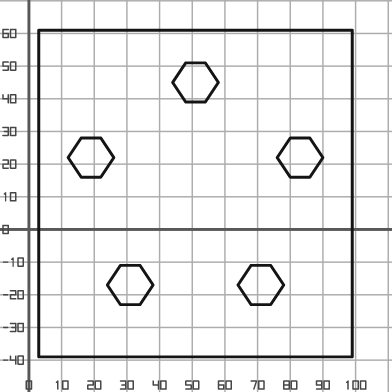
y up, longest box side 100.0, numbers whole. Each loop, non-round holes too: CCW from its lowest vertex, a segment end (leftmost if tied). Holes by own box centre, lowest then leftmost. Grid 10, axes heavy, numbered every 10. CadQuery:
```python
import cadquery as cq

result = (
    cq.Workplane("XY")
    .moveTo(3.0, -39.0)
    .lineTo(99.0, -39.0)
    .lineTo(99.0, 61.0)
    .lineTo(3.0, 61.0)
    .close()
    .moveTo(28.0, -23.0)
    .lineTo(34.0, -23.0)
    .lineTo(38.0, -17.0)
    .lineTo(34.0, -11.0)
    .lineTo(28.0, -11.0)
    .lineTo(24.0, -17.0)
    .close()
    .moveTo(68.0, -23.0)
    .lineTo(74.0, -23.0)
    .lineTo(78.0, -17.0)
    .lineTo(74.0, -11.0)
    .lineTo(68.0, -11.0)
    .lineTo(64.0, -17.0)
    .close()
    .moveTo(16.0, 16.0)
    .lineTo(22.0, 16.0)
    .lineTo(26.0, 22.0)
    .lineTo(22.0, 28.0)
    .lineTo(16.0, 28.0)
    .lineTo(12.0, 22.0)
    .close()
    .moveTo(80.0, 16.0)
    .lineTo(86.0, 16.0)
    .lineTo(90.0, 22.0)
    .lineTo(86.0, 28.0)
    .lineTo(80.0, 28.0)
    .lineTo(76.0, 22.0)
    .close()
    .moveTo(48.0, 39.0)
    .lineTo(54.0, 39.0)
    .lineTo(58.0, 45.0)
    .lineTo(54.0, 51.0)
    .lineTo(48.0, 51.0)
    .lineTo(44.0, 45.0)
    .close()
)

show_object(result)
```